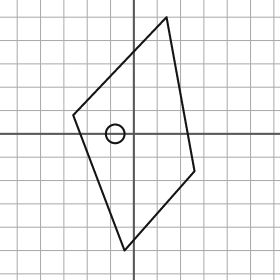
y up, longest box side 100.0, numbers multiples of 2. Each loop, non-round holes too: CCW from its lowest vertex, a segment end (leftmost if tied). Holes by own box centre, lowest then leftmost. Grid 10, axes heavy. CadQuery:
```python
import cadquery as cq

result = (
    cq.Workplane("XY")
    .moveTo(-4.0, -50.0)
    .lineTo(26.0, -16.0)
    .lineTo(14.0, 50.0)
    .lineTo(-26.0, 8.0)
    .close()
    .moveTo(-8.0, 0.0)
    .circle(4.0)
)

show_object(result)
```